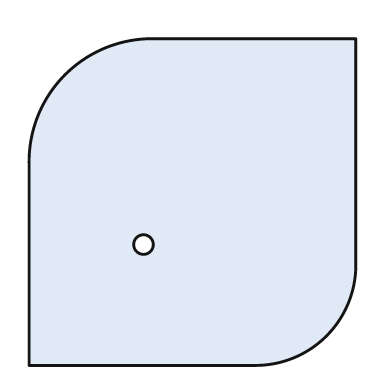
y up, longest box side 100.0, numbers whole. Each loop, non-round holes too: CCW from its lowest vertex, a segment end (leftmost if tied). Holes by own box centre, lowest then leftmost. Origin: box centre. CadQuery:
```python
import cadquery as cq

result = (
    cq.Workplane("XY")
    .moveTo(-50.0, -50.0)
    .lineTo(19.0, -50.0)
    .threePointArc((41.0, -41.0), (50.0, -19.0))
    .lineTo(50.0, 50.0)
    .lineTo(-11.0, 50.0)
    .threePointArc((-39.0, 39.0), (-50.0, 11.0))
    .close()
    .moveTo(-15.0, -13.0)
    .circle(3.0)
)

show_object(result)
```